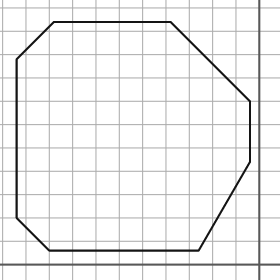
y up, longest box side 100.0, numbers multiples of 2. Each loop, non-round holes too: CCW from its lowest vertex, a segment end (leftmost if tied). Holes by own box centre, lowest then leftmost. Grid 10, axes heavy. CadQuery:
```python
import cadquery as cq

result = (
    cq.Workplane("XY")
    .moveTo(-90.0, 6.0)
    .lineTo(-26.0, 6.0)
    .lineTo(-4.0, 44.0)
    .lineTo(-4.0, 70.0)
    .lineTo(-38.0, 104.0)
    .lineTo(-88.0, 104.0)
    .lineTo(-104.0, 88.0)
    .lineTo(-104.0, 20.0)
    .close()
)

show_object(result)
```